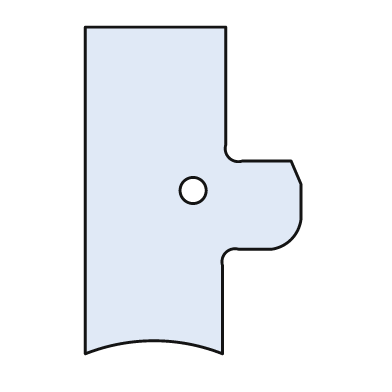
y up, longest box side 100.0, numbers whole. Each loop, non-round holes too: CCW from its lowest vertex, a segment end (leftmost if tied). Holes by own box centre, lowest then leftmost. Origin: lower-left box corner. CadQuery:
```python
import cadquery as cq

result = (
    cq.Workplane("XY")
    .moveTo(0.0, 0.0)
    .threePointArc((21.0, 4.0), (42.0, 0.0))
    .lineTo(42.0, 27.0)
    .threePointArc((43.0, 31.0), (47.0, 32.0))
    .lineTo(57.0, 32.0)
    .threePointArc((63.0, 35.0), (66.0, 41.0))
    .lineTo(66.0, 52.0)
    .lineTo(63.0, 59.0)
    .lineTo(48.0, 59.0)
    .threePointArc((44.0, 60.0), (43.0, 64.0))
    .lineTo(43.0, 100.0)
    .lineTo(0.0, 100.0)
    .close()
    .moveTo(33.0, 50.0)
    .circle(4.0)
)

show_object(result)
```